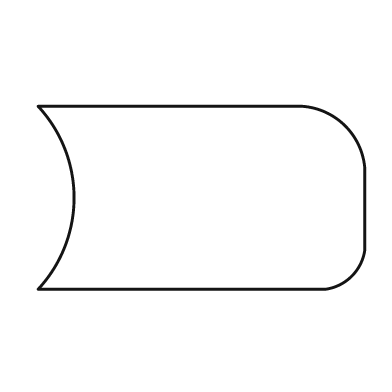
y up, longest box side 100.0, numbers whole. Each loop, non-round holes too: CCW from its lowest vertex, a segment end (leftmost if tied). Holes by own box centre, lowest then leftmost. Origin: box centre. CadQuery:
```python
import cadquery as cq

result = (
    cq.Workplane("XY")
    .moveTo(-50.0, -28.0)
    .lineTo(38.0, -28.0)
    .threePointArc((46.0, -24.0), (50.0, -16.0))
    .lineTo(50.0, 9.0)
    .threePointArc((44.0, 22.0), (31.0, 28.0))
    .lineTo(-50.0, 28.0)
    .threePointArc((-39.0, 0.0), (-50.0, -28.0))
    .close()
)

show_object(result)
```